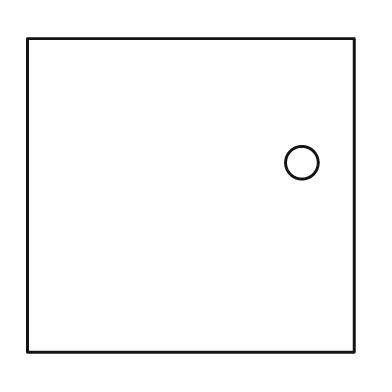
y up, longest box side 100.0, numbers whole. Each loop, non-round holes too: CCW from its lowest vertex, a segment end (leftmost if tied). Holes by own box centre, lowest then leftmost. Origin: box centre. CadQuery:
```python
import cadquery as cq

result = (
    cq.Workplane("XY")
    .moveTo(-50.0, -48.0)
    .lineTo(50.0, -48.0)
    .lineTo(50.0, 48.0)
    .lineTo(-50.0, 48.0)
    .close()
    .moveTo(34.0, 10.0)
    .circle(5.0)
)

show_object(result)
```